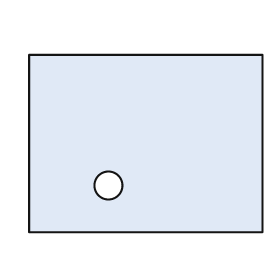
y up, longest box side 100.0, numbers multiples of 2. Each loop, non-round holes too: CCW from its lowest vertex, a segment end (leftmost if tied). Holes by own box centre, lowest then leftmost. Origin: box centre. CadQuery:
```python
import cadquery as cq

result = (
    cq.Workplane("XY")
    .moveTo(-50.0, -38.0)
    .lineTo(50.0, -38.0)
    .lineTo(50.0, 38.0)
    .lineTo(-50.0, 38.0)
    .close()
    .moveTo(-16.0, -18.0)
    .circle(6.0)
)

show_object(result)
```